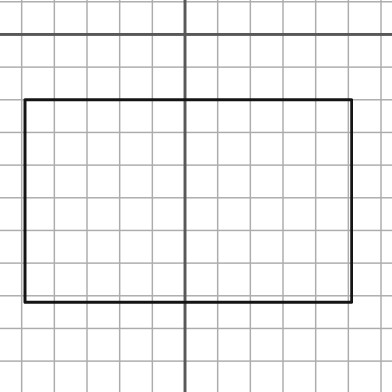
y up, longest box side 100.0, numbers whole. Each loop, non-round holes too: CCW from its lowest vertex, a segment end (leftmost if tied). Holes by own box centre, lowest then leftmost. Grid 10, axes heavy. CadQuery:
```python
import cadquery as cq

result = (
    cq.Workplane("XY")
    .moveTo(-49.0, -82.0)
    .lineTo(51.0, -82.0)
    .lineTo(51.0, -20.0)
    .lineTo(-49.0, -20.0)
    .close()
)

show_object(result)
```